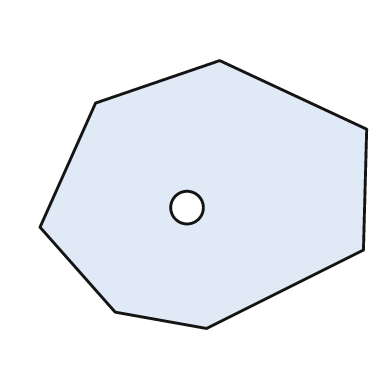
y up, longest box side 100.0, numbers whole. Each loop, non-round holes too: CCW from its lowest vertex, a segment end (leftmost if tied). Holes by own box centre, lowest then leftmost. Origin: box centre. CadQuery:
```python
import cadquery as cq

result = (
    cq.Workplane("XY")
    .moveTo(1.0, -41.0)
    .lineTo(49.0, -17.0)
    .lineTo(50.0, 20.0)
    .lineTo(5.0, 41.0)
    .lineTo(-33.0, 28.0)
    .lineTo(-50.0, -10.0)
    .lineTo(-27.0, -36.0)
    .close()
    .moveTo(-5.0, -4.0)
    .circle(5.0)
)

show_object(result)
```